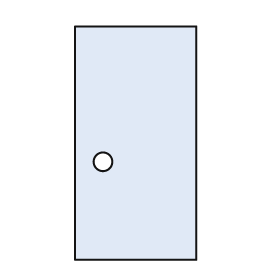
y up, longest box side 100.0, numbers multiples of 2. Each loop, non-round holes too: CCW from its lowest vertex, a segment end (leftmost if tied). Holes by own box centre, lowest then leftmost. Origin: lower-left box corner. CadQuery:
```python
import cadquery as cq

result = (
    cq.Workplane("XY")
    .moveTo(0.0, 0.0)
    .lineTo(52.0, 0.0)
    .lineTo(52.0, 100.0)
    .lineTo(0.0, 100.0)
    .close()
    .moveTo(12.0, 42.0)
    .circle(4.0)
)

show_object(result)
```